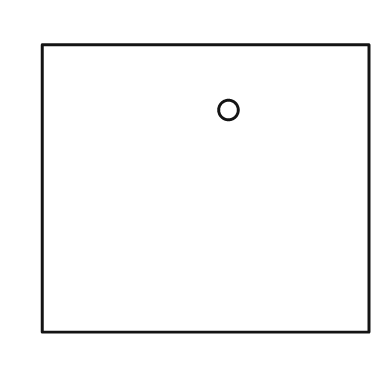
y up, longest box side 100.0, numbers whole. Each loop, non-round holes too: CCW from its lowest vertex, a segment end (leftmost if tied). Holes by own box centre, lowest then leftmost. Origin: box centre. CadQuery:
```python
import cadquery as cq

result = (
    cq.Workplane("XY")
    .moveTo(-50.0, -44.0)
    .lineTo(50.0, -44.0)
    .lineTo(50.0, 44.0)
    .lineTo(-50.0, 44.0)
    .close()
    .moveTo(7.0, 24.0)
    .circle(3.0)
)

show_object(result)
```